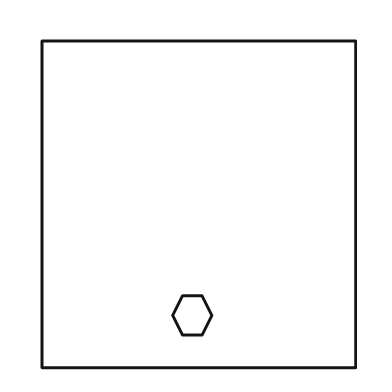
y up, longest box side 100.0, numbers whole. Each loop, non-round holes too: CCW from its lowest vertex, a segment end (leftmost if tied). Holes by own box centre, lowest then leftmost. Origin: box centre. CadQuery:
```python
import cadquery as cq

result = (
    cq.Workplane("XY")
    .moveTo(-48.0, -50.0)
    .lineTo(48.0, -50.0)
    .lineTo(48.0, 50.0)
    .lineTo(-48.0, 50.0)
    .close()
    .moveTo(-5.0, -40.0)
    .lineTo(1.0, -40.0)
    .lineTo(4.0, -34.0)
    .lineTo(1.0, -28.0)
    .lineTo(-5.0, -28.0)
    .lineTo(-8.0, -34.0)
    .close()
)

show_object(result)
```